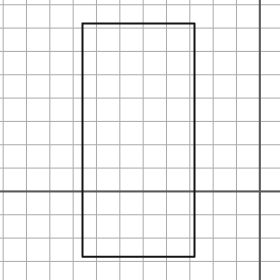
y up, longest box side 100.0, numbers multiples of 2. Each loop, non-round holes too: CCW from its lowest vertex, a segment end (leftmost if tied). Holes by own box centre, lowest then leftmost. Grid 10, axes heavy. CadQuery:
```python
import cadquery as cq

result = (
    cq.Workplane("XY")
    .moveTo(-76.0, -28.0)
    .lineTo(-28.0, -28.0)
    .lineTo(-28.0, 72.0)
    .lineTo(-76.0, 72.0)
    .close()
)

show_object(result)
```